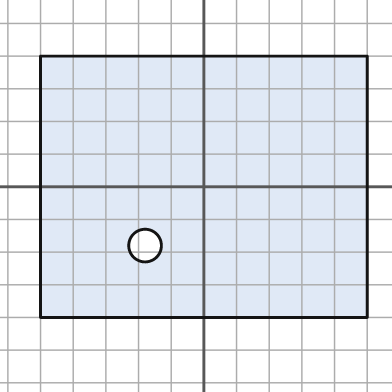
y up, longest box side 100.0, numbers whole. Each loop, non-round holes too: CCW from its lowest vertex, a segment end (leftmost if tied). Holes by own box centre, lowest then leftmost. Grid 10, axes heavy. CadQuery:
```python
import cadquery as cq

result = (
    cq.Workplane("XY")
    .moveTo(-50.0, -40.0)
    .lineTo(50.0, -40.0)
    .lineTo(50.0, 40.0)
    .lineTo(-50.0, 40.0)
    .close()
    .moveTo(-18.0, -18.0)
    .circle(5.0)
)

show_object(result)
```